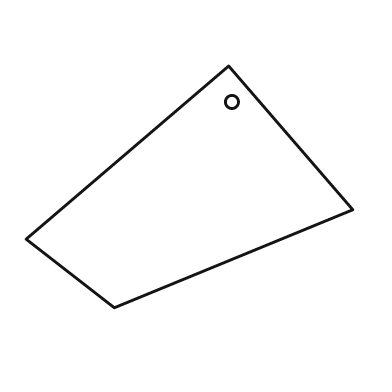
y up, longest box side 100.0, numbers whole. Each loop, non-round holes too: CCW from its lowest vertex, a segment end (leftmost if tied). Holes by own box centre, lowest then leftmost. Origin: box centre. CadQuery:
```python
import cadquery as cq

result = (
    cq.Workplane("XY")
    .moveTo(-23.0, -37.0)
    .lineTo(50.0, -7.0)
    .lineTo(12.0, 37.0)
    .lineTo(-50.0, -16.0)
    .close()
    .moveTo(13.0, 26.0)
    .circle(2.0)
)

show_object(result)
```